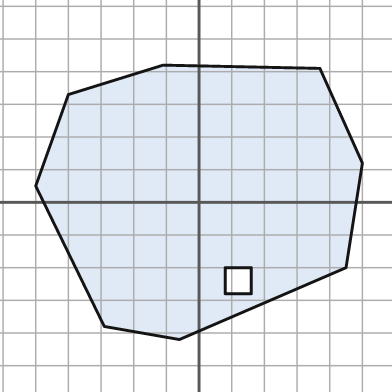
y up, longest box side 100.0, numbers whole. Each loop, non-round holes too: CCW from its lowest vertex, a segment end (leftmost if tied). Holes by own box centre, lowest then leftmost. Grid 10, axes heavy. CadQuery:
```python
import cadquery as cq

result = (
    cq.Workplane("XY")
    .moveTo(-6.0, -42.0)
    .lineTo(45.0, -20.0)
    .lineTo(50.0, 12.0)
    .lineTo(37.0, 41.0)
    .lineTo(-11.0, 42.0)
    .lineTo(-40.0, 33.0)
    .lineTo(-50.0, 5.0)
    .lineTo(-29.0, -38.0)
    .close()
    .moveTo(8.0, -28.0)
    .lineTo(16.0, -28.0)
    .lineTo(16.0, -20.0)
    .lineTo(8.0, -20.0)
    .close()
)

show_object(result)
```